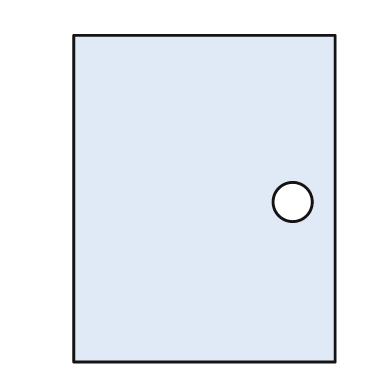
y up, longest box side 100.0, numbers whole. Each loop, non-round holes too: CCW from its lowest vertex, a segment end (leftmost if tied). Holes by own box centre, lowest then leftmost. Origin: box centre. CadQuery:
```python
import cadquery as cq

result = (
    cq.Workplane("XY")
    .moveTo(-40.0, -50.0)
    .lineTo(40.0, -50.0)
    .lineTo(40.0, 50.0)
    .lineTo(-40.0, 50.0)
    .close()
    .moveTo(27.0, -1.0)
    .circle(6.0)
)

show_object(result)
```